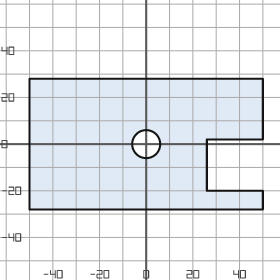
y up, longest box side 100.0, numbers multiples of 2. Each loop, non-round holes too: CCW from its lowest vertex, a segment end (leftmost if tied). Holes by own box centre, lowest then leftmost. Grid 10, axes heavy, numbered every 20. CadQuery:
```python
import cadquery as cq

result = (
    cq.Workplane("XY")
    .moveTo(-50.0, -28.0)
    .lineTo(50.0, -28.0)
    .lineTo(50.0, -20.0)
    .lineTo(26.0, -20.0)
    .lineTo(26.0, 2.0)
    .lineTo(50.0, 2.0)
    .lineTo(50.0, 28.0)
    .lineTo(-50.0, 28.0)
    .close()
    .moveTo(0.0, 0.0)
    .circle(6.0)
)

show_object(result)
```